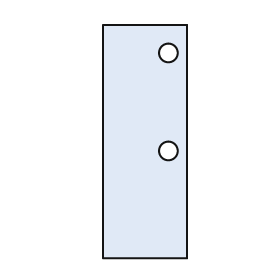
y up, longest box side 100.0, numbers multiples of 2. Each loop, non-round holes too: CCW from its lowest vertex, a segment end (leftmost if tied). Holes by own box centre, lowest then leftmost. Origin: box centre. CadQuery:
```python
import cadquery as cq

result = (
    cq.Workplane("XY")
    .moveTo(-18.0, -50.0)
    .lineTo(18.0, -50.0)
    .lineTo(18.0, 50.0)
    .lineTo(-18.0, 50.0)
    .close()
    .moveTo(10.0, -4.0)
    .circle(4.0)
    .moveTo(10.0, 38.0)
    .circle(4.0)
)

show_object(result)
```